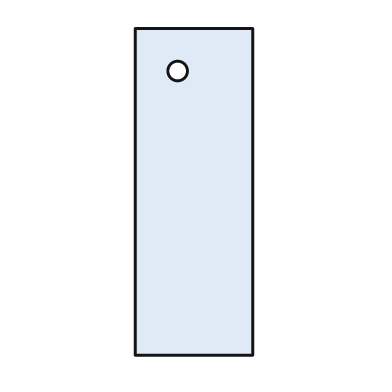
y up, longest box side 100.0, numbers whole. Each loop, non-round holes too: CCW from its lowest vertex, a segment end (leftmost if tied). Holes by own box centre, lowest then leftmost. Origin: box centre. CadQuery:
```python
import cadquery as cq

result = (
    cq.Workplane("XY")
    .moveTo(-18.0, -50.0)
    .lineTo(18.0, -50.0)
    .lineTo(18.0, 50.0)
    .lineTo(-18.0, 50.0)
    .close()
    .moveTo(-5.0, 37.0)
    .circle(3.0)
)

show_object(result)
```